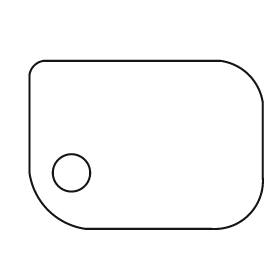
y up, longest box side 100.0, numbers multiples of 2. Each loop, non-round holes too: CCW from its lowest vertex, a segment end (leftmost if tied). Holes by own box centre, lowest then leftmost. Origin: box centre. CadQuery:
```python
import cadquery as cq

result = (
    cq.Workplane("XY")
    .moveTo(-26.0, -36.0)
    .lineTo(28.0, -36.0)
    .threePointArc((44.0, -30.0), (50.0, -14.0))
    .lineTo(50.0, 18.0)
    .threePointArc((44.0, 30.0), (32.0, 36.0))
    .lineTo(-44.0, 36.0)
    .threePointArc((-48.0, 34.0), (-50.0, 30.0))
    .lineTo(-50.0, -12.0)
    .threePointArc((-42.0, -28.0), (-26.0, -36.0))
    .close()
    .moveTo(-32.0, -12.0)
    .circle(8.0)
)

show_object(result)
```